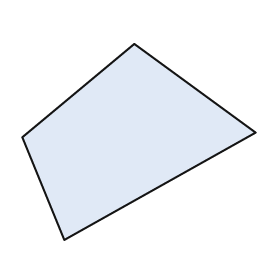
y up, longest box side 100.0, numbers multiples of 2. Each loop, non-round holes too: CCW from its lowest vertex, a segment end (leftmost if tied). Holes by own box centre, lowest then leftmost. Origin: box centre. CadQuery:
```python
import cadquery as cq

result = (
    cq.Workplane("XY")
    .moveTo(-32.0, -42.0)
    .lineTo(50.0, 4.0)
    .lineTo(-2.0, 42.0)
    .lineTo(-50.0, 2.0)
    .close()
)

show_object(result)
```